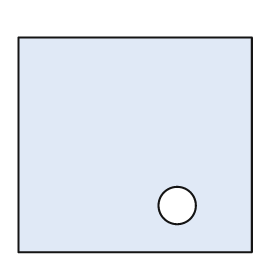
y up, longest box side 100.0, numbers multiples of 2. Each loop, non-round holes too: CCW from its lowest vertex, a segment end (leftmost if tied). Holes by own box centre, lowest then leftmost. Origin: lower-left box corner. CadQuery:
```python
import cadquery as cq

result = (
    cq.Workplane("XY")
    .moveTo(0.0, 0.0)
    .lineTo(100.0, 0.0)
    .lineTo(100.0, 92.0)
    .lineTo(0.0, 92.0)
    .close()
    .moveTo(68.0, 20.0)
    .circle(8.0)
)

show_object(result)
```